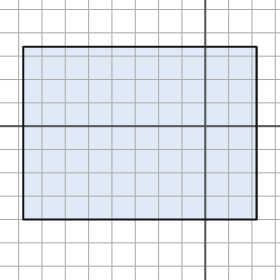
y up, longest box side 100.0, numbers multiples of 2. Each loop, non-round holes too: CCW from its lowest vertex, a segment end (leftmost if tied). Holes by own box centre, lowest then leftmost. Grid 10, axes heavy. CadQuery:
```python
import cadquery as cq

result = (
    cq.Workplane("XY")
    .moveTo(-78.0, -40.0)
    .lineTo(22.0, -40.0)
    .lineTo(22.0, 34.0)
    .lineTo(-78.0, 34.0)
    .close()
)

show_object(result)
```